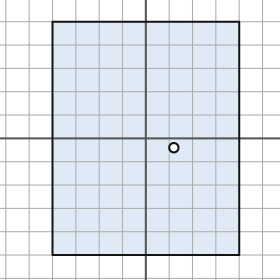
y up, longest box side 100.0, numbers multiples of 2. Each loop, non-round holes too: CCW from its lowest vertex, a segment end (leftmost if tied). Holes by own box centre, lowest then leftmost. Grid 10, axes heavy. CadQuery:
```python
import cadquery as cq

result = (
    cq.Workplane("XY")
    .moveTo(-40.0, -50.0)
    .lineTo(40.0, -50.0)
    .lineTo(40.0, 50.0)
    .lineTo(-40.0, 50.0)
    .close()
    .moveTo(12.0, -4.0)
    .circle(2.0)
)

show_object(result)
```